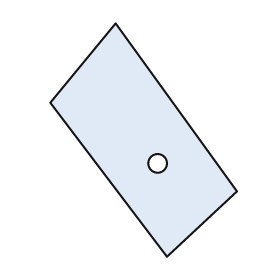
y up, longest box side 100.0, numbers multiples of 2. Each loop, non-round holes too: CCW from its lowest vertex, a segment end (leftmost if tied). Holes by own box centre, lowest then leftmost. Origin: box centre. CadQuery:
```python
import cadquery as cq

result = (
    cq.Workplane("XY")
    .moveTo(10.0, -50.0)
    .lineTo(40.0, -22.0)
    .lineTo(-12.0, 50.0)
    .lineTo(-40.0, 16.0)
    .close()
    .moveTo(6.0, -10.0)
    .circle(4.0)
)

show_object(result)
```